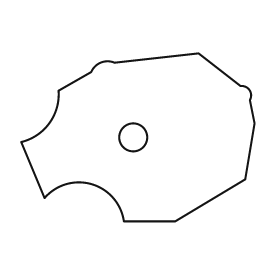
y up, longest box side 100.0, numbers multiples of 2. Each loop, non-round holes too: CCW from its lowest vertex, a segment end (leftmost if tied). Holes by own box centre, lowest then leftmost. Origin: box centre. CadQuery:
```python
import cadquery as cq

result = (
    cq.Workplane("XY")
    .moveTo(-6.0, -36.0)
    .lineTo(16.0, -36.0)
    .lineTo(46.0, -18.0)
    .lineTo(50.0, 6.0)
    .lineTo(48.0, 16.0)
    .threePointArc((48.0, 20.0), (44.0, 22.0))
    .lineTo(26.0, 36.0)
    .lineTo(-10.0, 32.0)
    .threePointArc((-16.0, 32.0), (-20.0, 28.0))
    .lineTo(-34.0, 20.0)
    .threePointArc((-38.0, 6.0), (-50.0, -2.0))
    .lineTo(-40.0, -26.0)
    .threePointArc((-20.0, -20.0), (-6.0, -36.0))
    .close()
    .moveTo(-2.0, 0.0)
    .circle(6.0)
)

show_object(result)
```